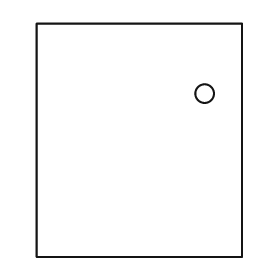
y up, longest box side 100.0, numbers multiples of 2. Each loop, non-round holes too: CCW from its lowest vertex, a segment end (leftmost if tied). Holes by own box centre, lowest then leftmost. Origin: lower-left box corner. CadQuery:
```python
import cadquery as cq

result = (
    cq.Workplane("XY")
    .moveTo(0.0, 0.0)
    .lineTo(88.0, 0.0)
    .lineTo(88.0, 100.0)
    .lineTo(0.0, 100.0)
    .close()
    .moveTo(72.0, 70.0)
    .circle(4.0)
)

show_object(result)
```